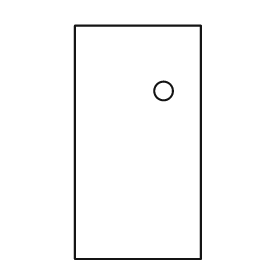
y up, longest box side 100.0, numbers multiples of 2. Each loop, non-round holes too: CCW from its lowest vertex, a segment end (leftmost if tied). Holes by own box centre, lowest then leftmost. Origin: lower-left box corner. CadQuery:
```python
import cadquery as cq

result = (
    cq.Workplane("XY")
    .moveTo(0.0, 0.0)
    .lineTo(54.0, 0.0)
    .lineTo(54.0, 100.0)
    .lineTo(0.0, 100.0)
    .close()
    .moveTo(38.0, 72.0)
    .circle(4.0)
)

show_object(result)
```